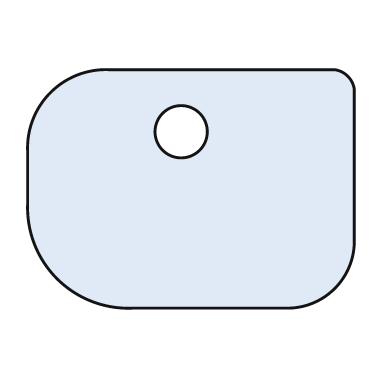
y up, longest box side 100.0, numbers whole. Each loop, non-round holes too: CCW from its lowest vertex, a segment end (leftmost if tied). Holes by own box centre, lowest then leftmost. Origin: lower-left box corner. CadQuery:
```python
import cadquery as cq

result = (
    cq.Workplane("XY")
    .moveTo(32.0, 0.0)
    .lineTo(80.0, 0.0)
    .threePointArc((94.0, 6.0), (100.0, 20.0))
    .lineTo(100.0, 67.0)
    .threePointArc((98.0, 71.0), (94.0, 73.0))
    .lineTo(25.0, 73.0)
    .threePointArc((7.0, 66.0), (0.0, 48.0))
    .lineTo(0.0, 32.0)
    .threePointArc((9.0, 9.0), (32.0, 0.0))
    .close()
    .moveTo(47.0, 54.0)
    .circle(8.0)
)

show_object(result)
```